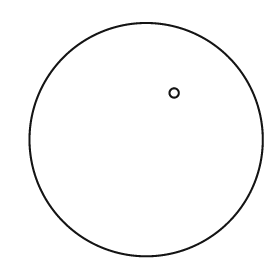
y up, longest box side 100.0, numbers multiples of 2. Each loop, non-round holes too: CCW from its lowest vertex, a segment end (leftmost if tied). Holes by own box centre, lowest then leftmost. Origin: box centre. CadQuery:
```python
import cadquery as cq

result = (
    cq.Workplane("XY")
    .moveTo(0.0, 0.0)
    .circle(50.0)
    .moveTo(12.0, 20.0)
    .circle(2.0)
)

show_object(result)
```